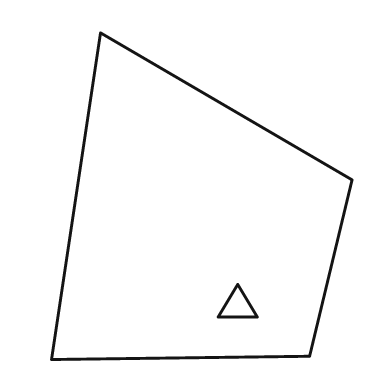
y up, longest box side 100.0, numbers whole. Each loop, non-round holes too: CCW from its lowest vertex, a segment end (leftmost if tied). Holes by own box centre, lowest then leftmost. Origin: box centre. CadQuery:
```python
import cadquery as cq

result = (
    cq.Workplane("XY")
    .moveTo(-46.0, -50.0)
    .lineTo(33.0, -49.0)
    .lineTo(46.0, 5.0)
    .lineTo(-31.0, 50.0)
    .close()
    .moveTo(5.0, -37.0)
    .lineTo(17.0, -37.0)
    .lineTo(11.0, -27.0)
    .close()
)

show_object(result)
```